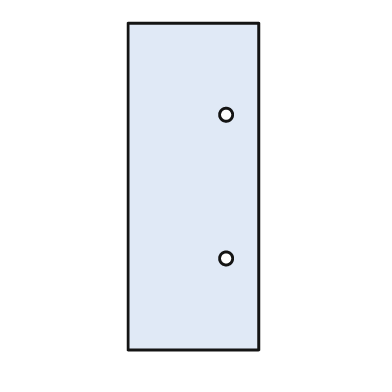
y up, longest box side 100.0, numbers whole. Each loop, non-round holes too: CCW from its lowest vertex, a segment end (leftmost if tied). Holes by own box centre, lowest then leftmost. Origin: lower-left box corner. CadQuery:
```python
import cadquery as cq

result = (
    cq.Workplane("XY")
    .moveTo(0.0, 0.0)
    .lineTo(40.0, 0.0)
    .lineTo(40.0, 100.0)
    .lineTo(0.0, 100.0)
    .close()
    .moveTo(30.0, 28.0)
    .circle(2.0)
    .moveTo(30.0, 72.0)
    .circle(2.0)
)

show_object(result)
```